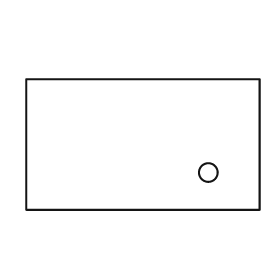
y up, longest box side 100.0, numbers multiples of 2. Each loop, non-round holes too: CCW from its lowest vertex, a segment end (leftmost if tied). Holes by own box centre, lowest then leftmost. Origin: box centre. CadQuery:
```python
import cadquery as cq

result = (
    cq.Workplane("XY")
    .moveTo(-50.0, -28.0)
    .lineTo(50.0, -28.0)
    .lineTo(50.0, 28.0)
    .lineTo(-50.0, 28.0)
    .close()
    .moveTo(28.0, -12.0)
    .circle(4.0)
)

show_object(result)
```